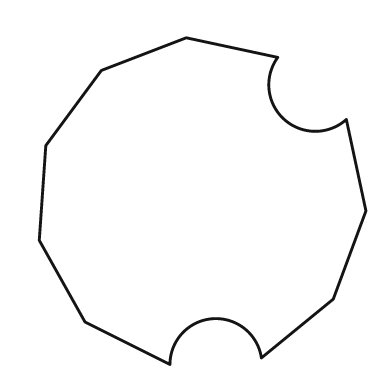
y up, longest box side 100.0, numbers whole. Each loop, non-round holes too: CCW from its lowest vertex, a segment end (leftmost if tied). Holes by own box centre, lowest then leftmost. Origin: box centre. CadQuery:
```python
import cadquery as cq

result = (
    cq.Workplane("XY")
    .moveTo(-10.0, -50.0)
    .threePointArc((3.0, -36.0), (18.0, -48.0))
    .lineTo(40.0, -30.0)
    .lineTo(50.0, -3.0)
    .lineTo(44.0, 25.0)
    .threePointArc((25.0, 25.0), (23.0, 44.0))
    .lineTo(-5.0, 50.0)
    .lineTo(-31.0, 40.0)
    .lineTo(-48.0, 17.0)
    .lineTo(-50.0, -12.0)
    .lineTo(-36.0, -37.0)
    .close()
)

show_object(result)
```